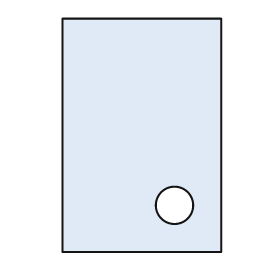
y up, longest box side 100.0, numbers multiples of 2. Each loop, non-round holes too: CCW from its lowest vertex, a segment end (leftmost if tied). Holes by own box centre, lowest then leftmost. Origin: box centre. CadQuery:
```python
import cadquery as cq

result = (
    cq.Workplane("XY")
    .moveTo(-34.0, -50.0)
    .lineTo(34.0, -50.0)
    .lineTo(34.0, 50.0)
    .lineTo(-34.0, 50.0)
    .close()
    .moveTo(14.0, -30.0)
    .circle(8.0)
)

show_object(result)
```